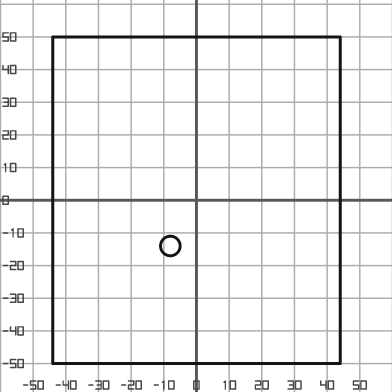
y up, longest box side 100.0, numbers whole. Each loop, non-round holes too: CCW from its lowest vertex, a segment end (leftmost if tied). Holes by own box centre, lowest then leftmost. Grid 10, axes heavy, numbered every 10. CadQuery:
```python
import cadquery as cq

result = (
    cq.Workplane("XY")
    .moveTo(-44.0, -50.0)
    .lineTo(44.0, -50.0)
    .lineTo(44.0, 50.0)
    .lineTo(-44.0, 50.0)
    .close()
    .moveTo(-8.0, -14.0)
    .circle(3.0)
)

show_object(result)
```